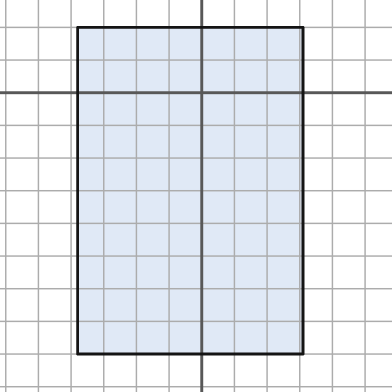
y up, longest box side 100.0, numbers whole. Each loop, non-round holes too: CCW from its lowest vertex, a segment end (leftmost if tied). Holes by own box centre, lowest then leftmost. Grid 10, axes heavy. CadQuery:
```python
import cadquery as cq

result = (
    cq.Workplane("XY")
    .moveTo(-38.0, -80.0)
    .lineTo(31.0, -80.0)
    .lineTo(31.0, 20.0)
    .lineTo(-38.0, 20.0)
    .close()
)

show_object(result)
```